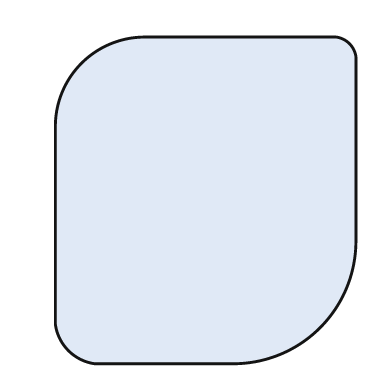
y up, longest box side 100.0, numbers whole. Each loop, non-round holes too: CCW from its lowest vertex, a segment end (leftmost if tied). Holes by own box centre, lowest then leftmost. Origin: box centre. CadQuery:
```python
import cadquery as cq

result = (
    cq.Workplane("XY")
    .moveTo(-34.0, -50.0)
    .lineTo(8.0, -50.0)
    .threePointArc((35.0, -39.0), (46.0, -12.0))
    .lineTo(46.0, 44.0)
    .threePointArc((44.0, 48.0), (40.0, 50.0))
    .lineTo(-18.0, 50.0)
    .threePointArc((-38.0, 42.0), (-46.0, 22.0))
    .lineTo(-46.0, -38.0)
    .threePointArc((-42.0, -46.0), (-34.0, -50.0))
    .close()
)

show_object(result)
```